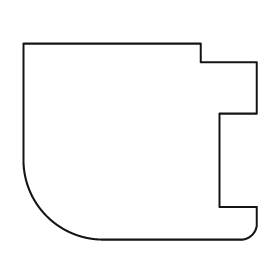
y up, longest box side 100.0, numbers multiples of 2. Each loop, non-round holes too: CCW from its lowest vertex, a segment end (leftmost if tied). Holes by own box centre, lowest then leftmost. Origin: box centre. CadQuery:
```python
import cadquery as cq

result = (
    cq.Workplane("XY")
    .moveTo(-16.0, -42.0)
    .lineTo(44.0, -42.0)
    .threePointArc((48.0, -40.0), (50.0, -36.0))
    .lineTo(50.0, -28.0)
    .lineTo(34.0, -28.0)
    .lineTo(34.0, 12.0)
    .lineTo(50.0, 12.0)
    .lineTo(50.0, 34.0)
    .lineTo(26.0, 34.0)
    .lineTo(26.0, 42.0)
    .lineTo(-50.0, 42.0)
    .lineTo(-50.0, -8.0)
    .threePointArc((-40.0, -32.0), (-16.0, -42.0))
    .close()
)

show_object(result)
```